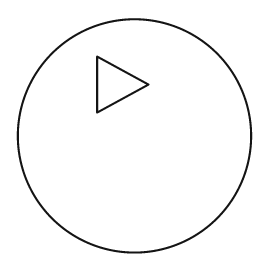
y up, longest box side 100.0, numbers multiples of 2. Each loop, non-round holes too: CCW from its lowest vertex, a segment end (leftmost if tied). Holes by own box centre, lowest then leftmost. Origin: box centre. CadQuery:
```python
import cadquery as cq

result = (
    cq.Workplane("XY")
    .moveTo(0.0, 0.0)
    .circle(50.0)
    .moveTo(-16.0, 10.0)
    .lineTo(6.0, 22.0)
    .lineTo(-16.0, 34.0)
    .close()
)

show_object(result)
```